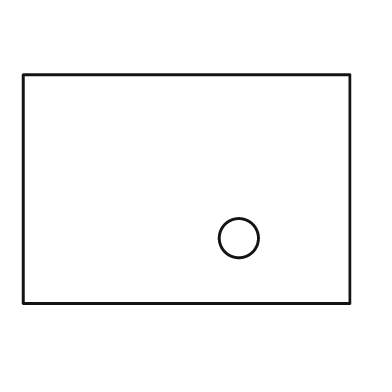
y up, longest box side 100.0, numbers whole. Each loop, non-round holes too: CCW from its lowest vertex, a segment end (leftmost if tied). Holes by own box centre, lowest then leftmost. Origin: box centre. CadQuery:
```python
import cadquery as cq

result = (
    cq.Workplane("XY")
    .moveTo(-50.0, -35.0)
    .lineTo(50.0, -35.0)
    .lineTo(50.0, 35.0)
    .lineTo(-50.0, 35.0)
    .close()
    .moveTo(16.0, -15.0)
    .circle(6.0)
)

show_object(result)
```